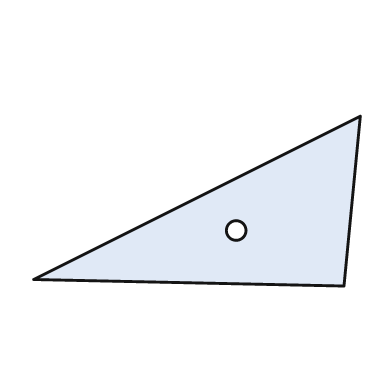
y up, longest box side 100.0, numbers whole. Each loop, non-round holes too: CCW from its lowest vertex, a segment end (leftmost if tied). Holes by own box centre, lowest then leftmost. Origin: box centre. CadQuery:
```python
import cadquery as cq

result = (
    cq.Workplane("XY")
    .moveTo(45.0, -26.0)
    .lineTo(50.0, 26.0)
    .lineTo(-50.0, -24.0)
    .close()
    .moveTo(12.0, -9.0)
    .circle(3.0)
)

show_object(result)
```